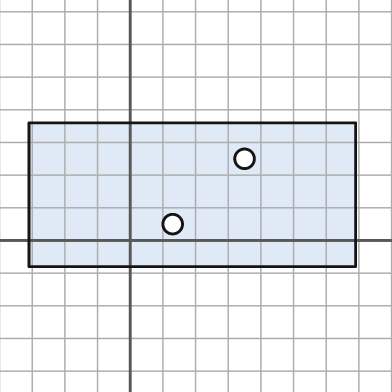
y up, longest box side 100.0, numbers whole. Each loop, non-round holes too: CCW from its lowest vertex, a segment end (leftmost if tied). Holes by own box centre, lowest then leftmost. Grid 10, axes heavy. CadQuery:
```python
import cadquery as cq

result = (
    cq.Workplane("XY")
    .moveTo(-31.0, -8.0)
    .lineTo(69.0, -8.0)
    .lineTo(69.0, 36.0)
    .lineTo(-31.0, 36.0)
    .close()
    .moveTo(13.0, 5.0)
    .circle(3.0)
    .moveTo(35.0, 25.0)
    .circle(3.0)
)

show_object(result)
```